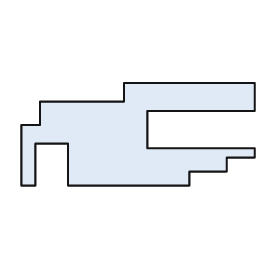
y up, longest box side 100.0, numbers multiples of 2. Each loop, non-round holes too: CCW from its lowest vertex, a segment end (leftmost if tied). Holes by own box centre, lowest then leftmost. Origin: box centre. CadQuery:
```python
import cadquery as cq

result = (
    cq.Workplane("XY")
    .moveTo(-50.0, -22.0)
    .lineTo(-44.0, -22.0)
    .lineTo(-44.0, -4.0)
    .lineTo(-30.0, -4.0)
    .lineTo(-30.0, -22.0)
    .lineTo(22.0, -22.0)
    .lineTo(22.0, -16.0)
    .lineTo(38.0, -16.0)
    .lineTo(38.0, -10.0)
    .lineTo(50.0, -10.0)
    .lineTo(50.0, -6.0)
    .lineTo(4.0, -6.0)
    .lineTo(4.0, 10.0)
    .lineTo(50.0, 10.0)
    .lineTo(50.0, 22.0)
    .lineTo(-6.0, 22.0)
    .lineTo(-6.0, 14.0)
    .lineTo(-42.0, 14.0)
    .lineTo(-42.0, 4.0)
    .lineTo(-50.0, 4.0)
    .close()
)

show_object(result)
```